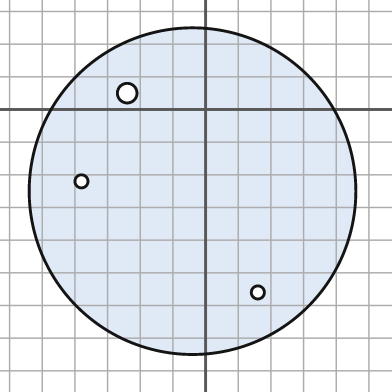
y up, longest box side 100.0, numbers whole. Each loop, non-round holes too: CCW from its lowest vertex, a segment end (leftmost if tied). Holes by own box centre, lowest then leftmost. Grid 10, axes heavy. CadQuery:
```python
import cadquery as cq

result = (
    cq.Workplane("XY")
    .moveTo(-4.0, -25.0)
    .circle(50.0)
    .moveTo(16.0, -56.0)
    .circle(2.0)
    .moveTo(-38.0, -22.0)
    .circle(2.0)
    .moveTo(-24.0, 5.0)
    .circle(3.0)
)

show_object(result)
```